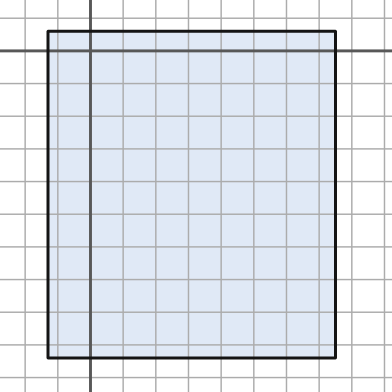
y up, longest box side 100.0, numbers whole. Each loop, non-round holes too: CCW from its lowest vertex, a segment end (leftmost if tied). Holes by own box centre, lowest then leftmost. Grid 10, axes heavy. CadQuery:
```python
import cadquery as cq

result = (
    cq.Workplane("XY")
    .moveTo(-13.0, -94.0)
    .lineTo(75.0, -94.0)
    .lineTo(75.0, 6.0)
    .lineTo(-13.0, 6.0)
    .close()
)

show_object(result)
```